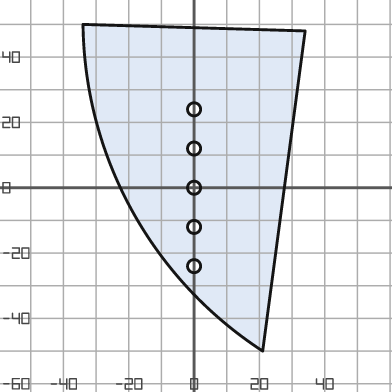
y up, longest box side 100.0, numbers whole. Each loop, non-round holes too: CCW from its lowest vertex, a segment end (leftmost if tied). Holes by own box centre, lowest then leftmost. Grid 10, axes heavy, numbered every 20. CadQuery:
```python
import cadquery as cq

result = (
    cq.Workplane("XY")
    .moveTo(21.0, -50.0)
    .lineTo(34.0, 48.0)
    .lineTo(-34.0, 50.0)
    .threePointArc((-19.0, -7.0), (21.0, -50.0))
    .close()
    .moveTo(0.0, -24.0)
    .circle(2.0)
    .moveTo(0.0, -12.0)
    .circle(2.0)
    .moveTo(0.0, 0.0)
    .circle(2.0)
    .moveTo(0.0, 12.0)
    .circle(2.0)
    .moveTo(0.0, 24.0)
    .circle(2.0)
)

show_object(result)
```